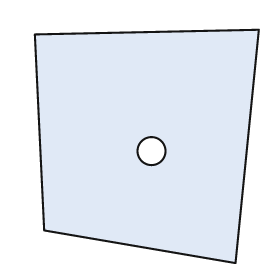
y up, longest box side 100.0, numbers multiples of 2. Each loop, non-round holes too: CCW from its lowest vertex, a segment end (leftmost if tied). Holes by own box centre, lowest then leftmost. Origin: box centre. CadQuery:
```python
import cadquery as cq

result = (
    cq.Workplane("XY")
    .moveTo(38.0, -50.0)
    .lineTo(48.0, 50.0)
    .lineTo(-48.0, 48.0)
    .lineTo(-44.0, -36.0)
    .close()
    .moveTo(2.0, -2.0)
    .circle(6.0)
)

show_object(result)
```